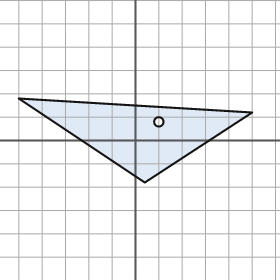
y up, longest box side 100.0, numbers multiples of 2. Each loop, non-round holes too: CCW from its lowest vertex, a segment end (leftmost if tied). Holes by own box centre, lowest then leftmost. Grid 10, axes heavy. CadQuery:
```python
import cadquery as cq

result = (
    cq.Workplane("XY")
    .moveTo(4.0, -18.0)
    .lineTo(50.0, 12.0)
    .lineTo(-50.0, 18.0)
    .close()
    .moveTo(10.0, 8.0)
    .circle(2.0)
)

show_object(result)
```